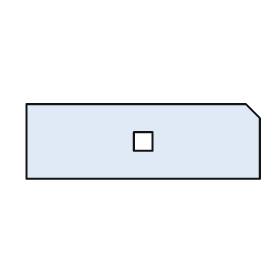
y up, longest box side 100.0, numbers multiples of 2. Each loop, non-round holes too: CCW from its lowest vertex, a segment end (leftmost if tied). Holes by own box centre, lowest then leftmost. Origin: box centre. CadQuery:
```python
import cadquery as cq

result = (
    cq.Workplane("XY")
    .moveTo(-50.0, -16.0)
    .lineTo(50.0, -16.0)
    .lineTo(50.0, 10.0)
    .lineTo(44.0, 16.0)
    .lineTo(-50.0, 16.0)
    .close()
    .moveTo(-4.0, -4.0)
    .lineTo(4.0, -4.0)
    .lineTo(4.0, 4.0)
    .lineTo(-4.0, 4.0)
    .close()
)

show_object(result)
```